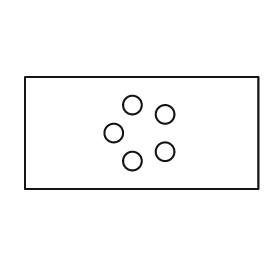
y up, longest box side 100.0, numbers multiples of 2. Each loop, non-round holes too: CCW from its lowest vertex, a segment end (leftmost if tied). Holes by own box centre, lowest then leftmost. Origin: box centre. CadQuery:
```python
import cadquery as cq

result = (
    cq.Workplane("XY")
    .moveTo(-50.0, -24.0)
    .lineTo(50.0, -24.0)
    .lineTo(50.0, 24.0)
    .lineTo(-50.0, 24.0)
    .close()
    .moveTo(-4.0, -12.0)
    .circle(4.0)
    .moveTo(10.0, -8.0)
    .circle(4.0)
    .moveTo(-12.0, 0.0)
    .circle(4.0)
    .moveTo(10.0, 8.0)
    .circle(4.0)
    .moveTo(-4.0, 12.0)
    .circle(4.0)
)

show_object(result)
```